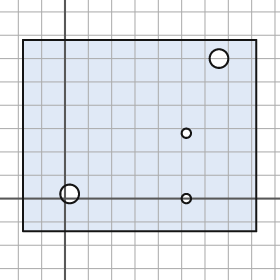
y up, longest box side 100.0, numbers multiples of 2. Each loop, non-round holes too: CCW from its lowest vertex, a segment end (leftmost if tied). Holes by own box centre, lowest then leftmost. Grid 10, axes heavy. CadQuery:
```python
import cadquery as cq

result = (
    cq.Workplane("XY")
    .moveTo(-18.0, -14.0)
    .lineTo(82.0, -14.0)
    .lineTo(82.0, 68.0)
    .lineTo(-18.0, 68.0)
    .close()
    .moveTo(52.0, 0.0)
    .circle(2.0)
    .moveTo(2.0, 2.0)
    .circle(4.0)
    .moveTo(52.0, 28.0)
    .circle(2.0)
    .moveTo(66.0, 60.0)
    .circle(4.0)
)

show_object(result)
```